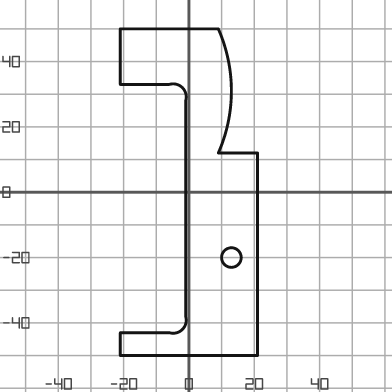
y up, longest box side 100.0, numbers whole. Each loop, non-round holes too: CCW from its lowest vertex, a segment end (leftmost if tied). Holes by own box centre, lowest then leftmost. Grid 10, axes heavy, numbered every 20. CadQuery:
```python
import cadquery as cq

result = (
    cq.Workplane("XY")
    .moveTo(-21.0, -50.0)
    .lineTo(21.0, -50.0)
    .lineTo(21.0, 12.0)
    .lineTo(9.0, 12.0)
    .threePointArc((13.0, 31.0), (9.0, 50.0))
    .lineTo(-21.0, 50.0)
    .lineTo(-21.0, 33.0)
    .lineTo(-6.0, 33.0)
    .threePointArc((-2.0, 32.0), (-1.0, 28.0))
    .lineTo(-1.0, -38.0)
    .threePointArc((-2.0, -42.0), (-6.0, -43.0))
    .lineTo(-21.0, -43.0)
    .close()
    .moveTo(13.0, -20.0)
    .circle(3.0)
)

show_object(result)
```